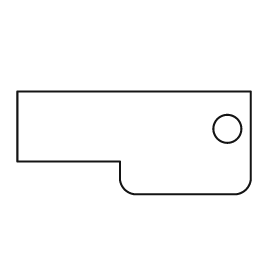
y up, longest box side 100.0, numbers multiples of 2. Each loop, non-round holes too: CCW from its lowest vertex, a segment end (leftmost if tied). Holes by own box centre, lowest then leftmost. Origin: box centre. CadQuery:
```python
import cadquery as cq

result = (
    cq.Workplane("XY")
    .moveTo(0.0, -22.0)
    .lineTo(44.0, -22.0)
    .threePointArc((48.0, -20.0), (50.0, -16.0))
    .lineTo(50.0, 22.0)
    .lineTo(-50.0, 22.0)
    .lineTo(-50.0, -8.0)
    .lineTo(-6.0, -8.0)
    .lineTo(-6.0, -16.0)
    .threePointArc((-4.0, -20.0), (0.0, -22.0))
    .close()
    .moveTo(40.0, 6.0)
    .circle(6.0)
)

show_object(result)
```